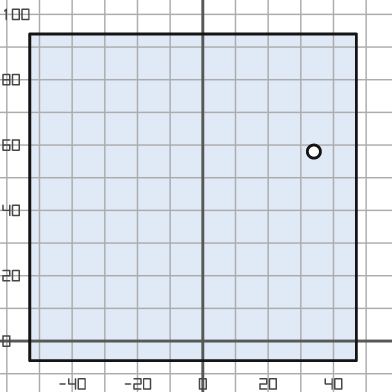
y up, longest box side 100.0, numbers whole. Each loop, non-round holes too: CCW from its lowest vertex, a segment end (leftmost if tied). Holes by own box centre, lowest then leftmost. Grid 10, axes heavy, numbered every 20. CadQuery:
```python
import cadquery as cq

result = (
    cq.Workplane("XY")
    .moveTo(-53.0, -6.0)
    .lineTo(47.0, -6.0)
    .lineTo(47.0, 94.0)
    .lineTo(-53.0, 94.0)
    .close()
    .moveTo(34.0, 58.0)
    .circle(2.0)
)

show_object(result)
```